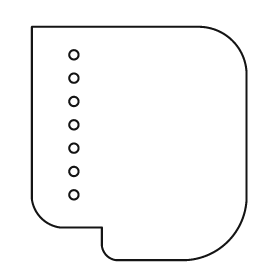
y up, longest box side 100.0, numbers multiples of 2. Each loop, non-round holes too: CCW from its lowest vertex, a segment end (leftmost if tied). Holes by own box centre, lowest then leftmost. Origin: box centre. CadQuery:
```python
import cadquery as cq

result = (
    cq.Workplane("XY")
    .moveTo(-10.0, -50.0)
    .lineTo(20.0, -50.0)
    .threePointArc((38.0, -42.0), (46.0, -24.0))
    .lineTo(46.0, 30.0)
    .threePointArc((40.0, 44.0), (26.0, 50.0))
    .lineTo(-46.0, 50.0)
    .lineTo(-46.0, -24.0)
    .threePointArc((-42.0, -32.0), (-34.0, -36.0))
    .lineTo(-16.0, -36.0)
    .lineTo(-16.0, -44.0)
    .threePointArc((-14.0, -48.0), (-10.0, -50.0))
    .close()
    .moveTo(-28.0, -22.0)
    .circle(2.0)
    .moveTo(-28.0, -12.0)
    .circle(2.0)
    .moveTo(-28.0, -2.0)
    .circle(2.0)
    .moveTo(-28.0, 8.0)
    .circle(2.0)
    .moveTo(-28.0, 18.0)
    .circle(2.0)
    .moveTo(-28.0, 28.0)
    .circle(2.0)
    .moveTo(-28.0, 38.0)
    .circle(2.0)
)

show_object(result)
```